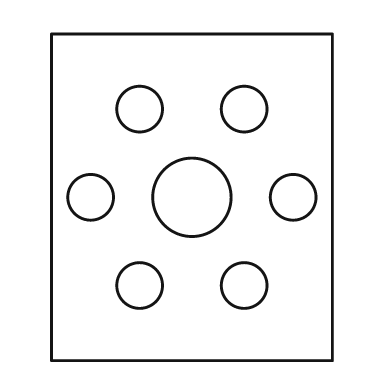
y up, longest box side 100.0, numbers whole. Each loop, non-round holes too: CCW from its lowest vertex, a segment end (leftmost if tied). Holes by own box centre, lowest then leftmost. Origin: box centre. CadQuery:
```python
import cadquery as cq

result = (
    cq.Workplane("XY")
    .moveTo(-43.0, -50.0)
    .lineTo(43.0, -50.0)
    .lineTo(43.0, 50.0)
    .lineTo(-43.0, 50.0)
    .close()
    .moveTo(-16.0, -27.0)
    .circle(7.0)
    .moveTo(16.0, -27.0)
    .circle(7.0)
    .moveTo(-31.0, 0.0)
    .circle(7.0)
    .moveTo(0.0, 0.0)
    .circle(12.0)
    .moveTo(31.0, 0.0)
    .circle(7.0)
    .moveTo(-16.0, 27.0)
    .circle(7.0)
    .moveTo(16.0, 27.0)
    .circle(7.0)
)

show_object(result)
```